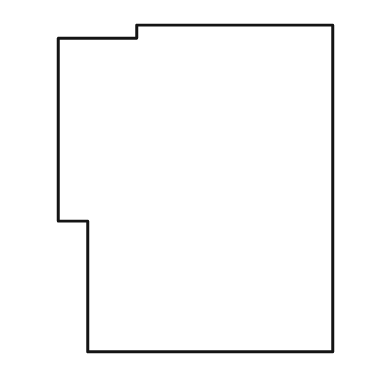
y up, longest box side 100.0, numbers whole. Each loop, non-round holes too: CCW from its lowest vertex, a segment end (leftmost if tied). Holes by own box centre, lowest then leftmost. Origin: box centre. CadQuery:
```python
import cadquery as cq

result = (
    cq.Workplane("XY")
    .moveTo(-33.0, -50.0)
    .lineTo(42.0, -50.0)
    .lineTo(42.0, 50.0)
    .lineTo(-18.0, 50.0)
    .lineTo(-18.0, 46.0)
    .lineTo(-42.0, 46.0)
    .lineTo(-42.0, -10.0)
    .lineTo(-33.0, -10.0)
    .close()
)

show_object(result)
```